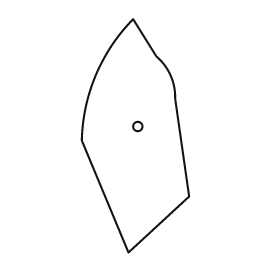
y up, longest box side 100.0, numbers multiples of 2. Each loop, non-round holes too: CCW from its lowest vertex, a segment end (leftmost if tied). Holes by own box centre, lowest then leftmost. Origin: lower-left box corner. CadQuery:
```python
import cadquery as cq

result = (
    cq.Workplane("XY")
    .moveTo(20.0, 0.0)
    .lineTo(46.0, 24.0)
    .lineTo(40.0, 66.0)
    .threePointArc((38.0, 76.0), (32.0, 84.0))
    .lineTo(22.0, 100.0)
    .threePointArc((6.0, 76.0), (0.0, 48.0))
    .close()
    .moveTo(24.0, 54.0)
    .circle(2.0)
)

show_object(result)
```